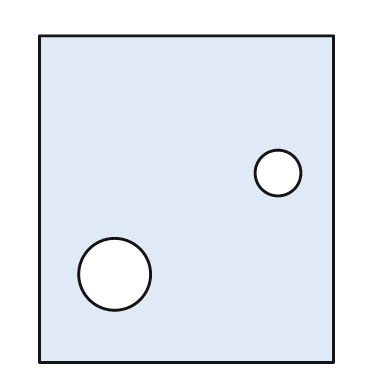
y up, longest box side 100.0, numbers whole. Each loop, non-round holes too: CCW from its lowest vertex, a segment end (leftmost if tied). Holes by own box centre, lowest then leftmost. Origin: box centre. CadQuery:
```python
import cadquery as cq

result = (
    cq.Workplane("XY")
    .moveTo(-45.0, -50.0)
    .lineTo(45.0, -50.0)
    .lineTo(45.0, 50.0)
    .lineTo(-45.0, 50.0)
    .close()
    .moveTo(-22.0, -23.0)
    .circle(11.0)
    .moveTo(28.0, 8.0)
    .circle(7.0)
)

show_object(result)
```